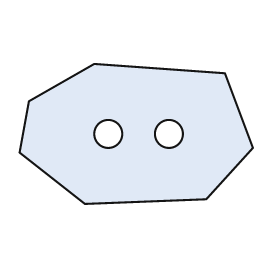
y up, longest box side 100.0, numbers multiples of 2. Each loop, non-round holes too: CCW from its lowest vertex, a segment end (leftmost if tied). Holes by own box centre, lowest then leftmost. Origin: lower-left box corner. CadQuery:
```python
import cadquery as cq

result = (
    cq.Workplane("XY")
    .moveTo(28.0, 0.0)
    .lineTo(80.0, 2.0)
    .lineTo(100.0, 24.0)
    .lineTo(88.0, 56.0)
    .lineTo(32.0, 60.0)
    .lineTo(4.0, 44.0)
    .lineTo(0.0, 22.0)
    .close()
    .moveTo(38.0, 30.0)
    .circle(6.0)
    .moveTo(64.0, 30.0)
    .circle(6.0)
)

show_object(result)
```